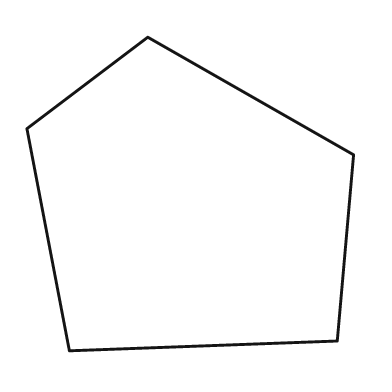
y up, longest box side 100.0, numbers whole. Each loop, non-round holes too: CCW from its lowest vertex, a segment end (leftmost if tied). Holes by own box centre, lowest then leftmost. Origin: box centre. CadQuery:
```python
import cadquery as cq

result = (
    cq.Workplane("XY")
    .moveTo(-37.0, -48.0)
    .lineTo(45.0, -45.0)
    .lineTo(50.0, 12.0)
    .lineTo(-13.0, 48.0)
    .lineTo(-50.0, 20.0)
    .close()
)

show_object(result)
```